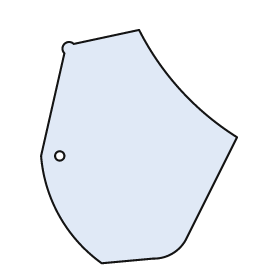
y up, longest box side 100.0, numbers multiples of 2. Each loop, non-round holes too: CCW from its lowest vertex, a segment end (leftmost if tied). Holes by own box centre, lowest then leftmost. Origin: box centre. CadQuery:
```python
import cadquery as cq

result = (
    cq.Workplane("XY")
    .moveTo(-16.0, -50.0)
    .lineTo(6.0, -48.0)
    .threePointArc((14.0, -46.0), (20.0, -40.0))
    .lineTo(42.0, 4.0)
    .threePointArc((18.0, 24.0), (0.0, 50.0))
    .lineTo(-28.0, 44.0)
    .threePointArc((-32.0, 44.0), (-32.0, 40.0))
    .lineTo(-42.0, -4.0)
    .threePointArc((-34.0, -30.0), (-16.0, -50.0))
    .close()
    .moveTo(-34.0, -4.0)
    .circle(2.0)
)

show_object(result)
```